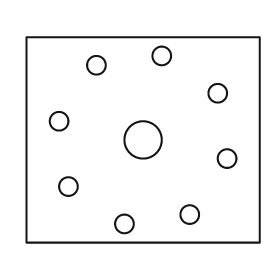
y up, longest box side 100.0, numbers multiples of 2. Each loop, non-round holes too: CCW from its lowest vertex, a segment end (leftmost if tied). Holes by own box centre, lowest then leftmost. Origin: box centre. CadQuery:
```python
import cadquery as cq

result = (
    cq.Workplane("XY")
    .moveTo(-50.0, -44.0)
    .lineTo(50.0, -44.0)
    .lineTo(50.0, 44.0)
    .lineTo(-50.0, 44.0)
    .close()
    .moveTo(-8.0, -36.0)
    .circle(4.0)
    .moveTo(20.0, -32.0)
    .circle(4.0)
    .moveTo(-32.0, -20.0)
    .circle(4.0)
    .moveTo(36.0, -8.0)
    .circle(4.0)
    .moveTo(0.0, 0.0)
    .circle(8.0)
    .moveTo(-36.0, 8.0)
    .circle(4.0)
    .moveTo(32.0, 20.0)
    .circle(4.0)
    .moveTo(-20.0, 32.0)
    .circle(4.0)
    .moveTo(8.0, 36.0)
    .circle(4.0)
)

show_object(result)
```